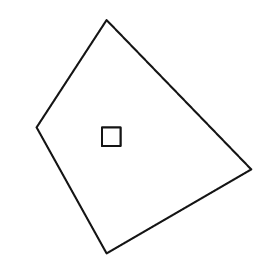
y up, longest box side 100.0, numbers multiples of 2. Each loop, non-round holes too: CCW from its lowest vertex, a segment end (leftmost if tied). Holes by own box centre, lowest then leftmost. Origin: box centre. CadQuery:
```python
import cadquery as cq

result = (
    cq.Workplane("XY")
    .moveTo(-16.0, -50.0)
    .lineTo(46.0, -14.0)
    .lineTo(-16.0, 50.0)
    .lineTo(-46.0, 4.0)
    .close()
    .moveTo(-18.0, -4.0)
    .lineTo(-10.0, -4.0)
    .lineTo(-10.0, 4.0)
    .lineTo(-18.0, 4.0)
    .close()
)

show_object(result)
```